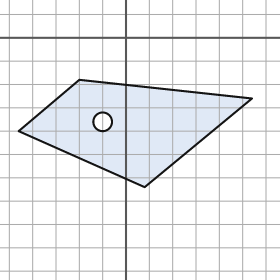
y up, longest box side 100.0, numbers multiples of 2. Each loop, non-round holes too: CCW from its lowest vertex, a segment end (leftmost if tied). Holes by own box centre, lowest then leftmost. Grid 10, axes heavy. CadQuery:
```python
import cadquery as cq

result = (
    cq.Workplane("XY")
    .moveTo(8.0, -64.0)
    .lineTo(54.0, -26.0)
    .lineTo(-20.0, -18.0)
    .lineTo(-46.0, -40.0)
    .close()
    .moveTo(-10.0, -36.0)
    .circle(4.0)
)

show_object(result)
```